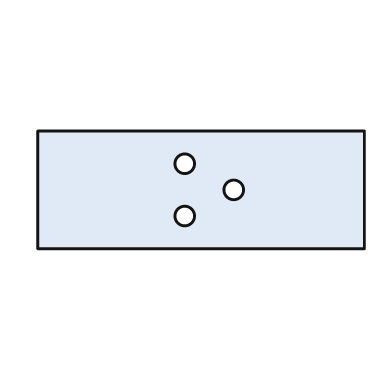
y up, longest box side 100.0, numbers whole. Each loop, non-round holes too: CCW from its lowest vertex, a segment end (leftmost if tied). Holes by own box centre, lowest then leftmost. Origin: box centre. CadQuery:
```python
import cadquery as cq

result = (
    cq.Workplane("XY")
    .moveTo(-50.0, -18.0)
    .lineTo(50.0, -18.0)
    .lineTo(50.0, 18.0)
    .lineTo(-50.0, 18.0)
    .close()
    .moveTo(-5.0, -8.0)
    .circle(3.0)
    .moveTo(10.0, 0.0)
    .circle(3.0)
    .moveTo(-5.0, 8.0)
    .circle(3.0)
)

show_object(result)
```